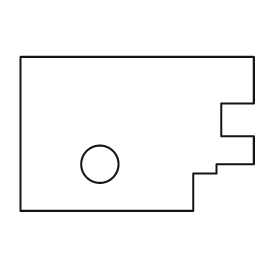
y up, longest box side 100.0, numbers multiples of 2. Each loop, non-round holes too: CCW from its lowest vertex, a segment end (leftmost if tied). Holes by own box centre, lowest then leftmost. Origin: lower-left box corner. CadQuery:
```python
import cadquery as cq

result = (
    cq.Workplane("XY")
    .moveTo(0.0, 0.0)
    .lineTo(74.0, 0.0)
    .lineTo(74.0, 16.0)
    .lineTo(84.0, 16.0)
    .lineTo(84.0, 20.0)
    .lineTo(100.0, 20.0)
    .lineTo(100.0, 32.0)
    .lineTo(86.0, 32.0)
    .lineTo(86.0, 46.0)
    .lineTo(100.0, 46.0)
    .lineTo(100.0, 66.0)
    .lineTo(0.0, 66.0)
    .close()
    .moveTo(34.0, 20.0)
    .circle(8.0)
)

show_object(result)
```